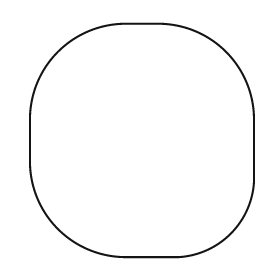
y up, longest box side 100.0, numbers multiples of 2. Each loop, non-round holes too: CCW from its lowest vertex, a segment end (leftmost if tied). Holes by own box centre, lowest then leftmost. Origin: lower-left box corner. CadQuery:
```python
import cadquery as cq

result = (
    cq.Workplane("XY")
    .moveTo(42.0, 0.0)
    .lineTo(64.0, 0.0)
    .threePointArc((86.0, 10.0), (96.0, 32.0))
    .lineTo(96.0, 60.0)
    .threePointArc((84.0, 88.0), (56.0, 100.0))
    .lineTo(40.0, 100.0)
    .threePointArc((12.0, 88.0), (0.0, 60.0))
    .lineTo(0.0, 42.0)
    .threePointArc((12.0, 12.0), (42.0, 0.0))
    .close()
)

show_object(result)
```